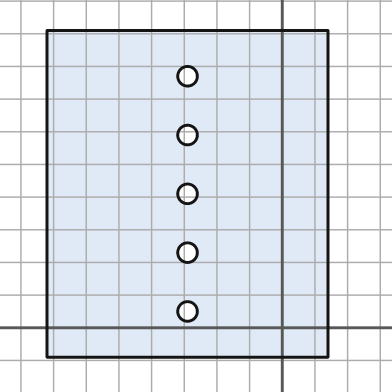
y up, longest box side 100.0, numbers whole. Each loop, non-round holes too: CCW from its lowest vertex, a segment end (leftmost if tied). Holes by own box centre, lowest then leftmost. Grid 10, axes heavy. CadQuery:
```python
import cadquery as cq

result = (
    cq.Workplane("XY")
    .moveTo(-72.0, -9.0)
    .lineTo(14.0, -9.0)
    .lineTo(14.0, 91.0)
    .lineTo(-72.0, 91.0)
    .close()
    .moveTo(-29.0, 5.0)
    .circle(3.0)
    .moveTo(-29.0, 23.0)
    .circle(3.0)
    .moveTo(-29.0, 41.0)
    .circle(3.0)
    .moveTo(-29.0, 59.0)
    .circle(3.0)
    .moveTo(-29.0, 77.0)
    .circle(3.0)
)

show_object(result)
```